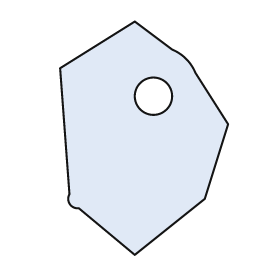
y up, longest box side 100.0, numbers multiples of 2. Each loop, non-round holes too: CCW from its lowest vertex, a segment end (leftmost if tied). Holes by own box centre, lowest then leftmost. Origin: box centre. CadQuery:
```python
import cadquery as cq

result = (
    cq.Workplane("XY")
    .moveTo(-4.0, -50.0)
    .lineTo(26.0, -26.0)
    .lineTo(36.0, 6.0)
    .lineTo(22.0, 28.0)
    .threePointArc((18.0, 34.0), (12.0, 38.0))
    .lineTo(-4.0, 50.0)
    .lineTo(-36.0, 30.0)
    .lineTo(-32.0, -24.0)
    .threePointArc((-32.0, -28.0), (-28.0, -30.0))
    .close()
    .moveTo(4.0, 18.0)
    .circle(8.0)
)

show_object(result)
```